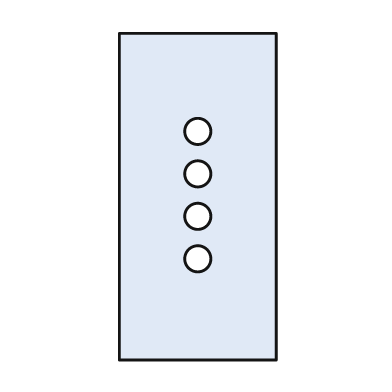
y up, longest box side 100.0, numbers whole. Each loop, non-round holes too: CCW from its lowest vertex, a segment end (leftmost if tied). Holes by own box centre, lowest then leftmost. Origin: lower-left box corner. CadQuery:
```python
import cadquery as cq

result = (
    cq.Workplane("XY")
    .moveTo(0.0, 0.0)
    .lineTo(48.0, 0.0)
    .lineTo(48.0, 100.0)
    .lineTo(0.0, 100.0)
    .close()
    .moveTo(24.0, 31.0)
    .circle(4.0)
    .moveTo(24.0, 44.0)
    .circle(4.0)
    .moveTo(24.0, 57.0)
    .circle(4.0)
    .moveTo(24.0, 70.0)
    .circle(4.0)
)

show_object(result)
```